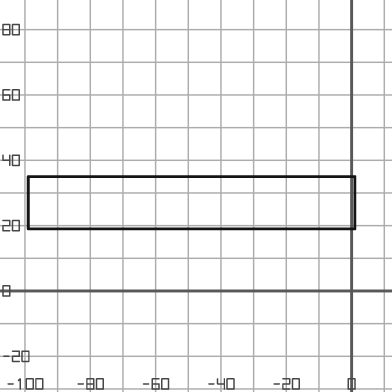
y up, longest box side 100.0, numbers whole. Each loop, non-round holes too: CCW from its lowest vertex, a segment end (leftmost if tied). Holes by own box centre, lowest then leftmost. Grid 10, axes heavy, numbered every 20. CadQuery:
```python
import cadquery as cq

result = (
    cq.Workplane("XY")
    .moveTo(-99.0, 19.0)
    .lineTo(1.0, 19.0)
    .lineTo(1.0, 35.0)
    .lineTo(-99.0, 35.0)
    .close()
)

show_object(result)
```